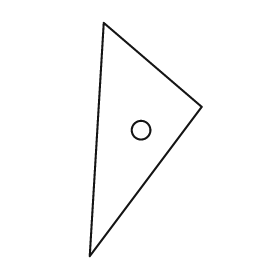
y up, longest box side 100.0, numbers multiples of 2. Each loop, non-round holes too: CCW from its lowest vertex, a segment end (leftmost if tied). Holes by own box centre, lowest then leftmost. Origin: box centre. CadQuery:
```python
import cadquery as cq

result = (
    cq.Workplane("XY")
    .moveTo(-24.0, -50.0)
    .lineTo(24.0, 14.0)
    .lineTo(-18.0, 50.0)
    .close()
    .moveTo(-2.0, 4.0)
    .circle(4.0)
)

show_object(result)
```